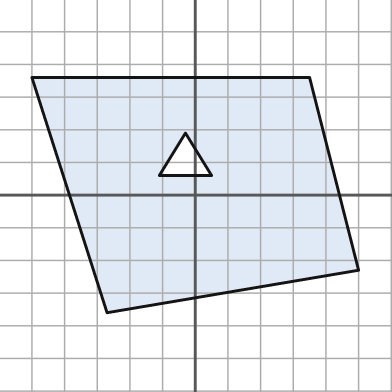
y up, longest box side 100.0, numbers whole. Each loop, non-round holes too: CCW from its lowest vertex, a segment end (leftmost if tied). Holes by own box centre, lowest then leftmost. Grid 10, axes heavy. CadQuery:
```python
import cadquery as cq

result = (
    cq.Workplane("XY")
    .moveTo(-27.0, -36.0)
    .lineTo(50.0, -23.0)
    .lineTo(35.0, 36.0)
    .lineTo(-50.0, 36.0)
    .close()
    .moveTo(-11.0, 6.0)
    .lineTo(5.0, 6.0)
    .lineTo(-3.0, 19.0)
    .close()
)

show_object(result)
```